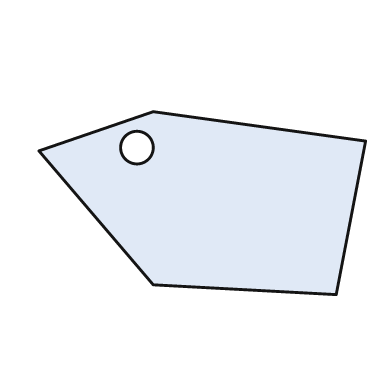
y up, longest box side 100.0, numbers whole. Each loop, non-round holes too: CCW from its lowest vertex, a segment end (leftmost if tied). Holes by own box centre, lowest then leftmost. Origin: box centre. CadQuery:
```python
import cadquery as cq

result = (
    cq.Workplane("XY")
    .moveTo(41.0, -28.0)
    .lineTo(50.0, 19.0)
    .lineTo(-15.0, 28.0)
    .lineTo(-50.0, 16.0)
    .lineTo(-15.0, -25.0)
    .close()
    .moveTo(-20.0, 17.0)
    .circle(5.0)
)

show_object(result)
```